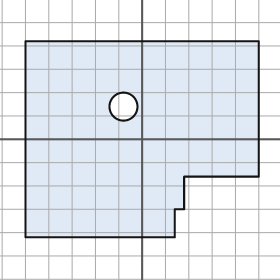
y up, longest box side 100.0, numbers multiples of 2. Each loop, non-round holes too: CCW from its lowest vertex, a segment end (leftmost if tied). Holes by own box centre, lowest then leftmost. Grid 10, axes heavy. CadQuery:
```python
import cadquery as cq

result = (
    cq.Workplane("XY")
    .moveTo(-50.0, -42.0)
    .lineTo(14.0, -42.0)
    .lineTo(14.0, -30.0)
    .lineTo(18.0, -30.0)
    .lineTo(18.0, -16.0)
    .lineTo(50.0, -16.0)
    .lineTo(50.0, 42.0)
    .lineTo(-50.0, 42.0)
    .close()
    .moveTo(-8.0, 14.0)
    .circle(6.0)
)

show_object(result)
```